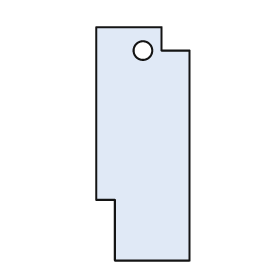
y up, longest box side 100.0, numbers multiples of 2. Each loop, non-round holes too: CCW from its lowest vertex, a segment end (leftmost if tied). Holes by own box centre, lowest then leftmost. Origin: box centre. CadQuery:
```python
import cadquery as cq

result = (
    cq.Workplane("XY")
    .moveTo(-12.0, -50.0)
    .lineTo(20.0, -50.0)
    .lineTo(20.0, 40.0)
    .lineTo(8.0, 40.0)
    .lineTo(8.0, 50.0)
    .lineTo(-20.0, 50.0)
    .lineTo(-20.0, -24.0)
    .lineTo(-12.0, -24.0)
    .close()
    .moveTo(0.0, 40.0)
    .circle(4.0)
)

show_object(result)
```